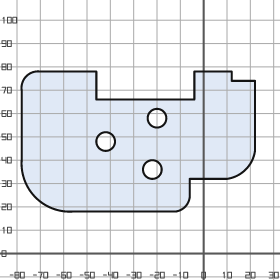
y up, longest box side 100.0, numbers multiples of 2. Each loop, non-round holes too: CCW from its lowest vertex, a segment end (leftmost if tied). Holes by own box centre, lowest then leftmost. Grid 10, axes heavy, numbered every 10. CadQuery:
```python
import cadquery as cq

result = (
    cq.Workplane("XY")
    .moveTo(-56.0, 18.0)
    .lineTo(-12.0, 18.0)
    .threePointArc((-8.0, 20.0), (-6.0, 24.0))
    .lineTo(-6.0, 32.0)
    .lineTo(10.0, 32.0)
    .threePointArc((18.0, 36.0), (22.0, 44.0))
    .lineTo(22.0, 74.0)
    .lineTo(12.0, 74.0)
    .lineTo(12.0, 78.0)
    .lineTo(-4.0, 78.0)
    .lineTo(-4.0, 66.0)
    .lineTo(-46.0, 66.0)
    .lineTo(-46.0, 78.0)
    .lineTo(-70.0, 78.0)
    .threePointArc((-76.0, 76.0), (-78.0, 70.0))
    .lineTo(-78.0, 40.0)
    .threePointArc((-72.0, 24.0), (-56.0, 18.0))
    .close()
    .moveTo(-22.0, 36.0)
    .circle(4.0)
    .moveTo(-42.0, 48.0)
    .circle(4.0)
    .moveTo(-20.0, 58.0)
    .circle(4.0)
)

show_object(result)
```